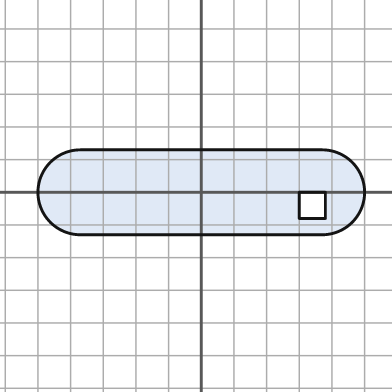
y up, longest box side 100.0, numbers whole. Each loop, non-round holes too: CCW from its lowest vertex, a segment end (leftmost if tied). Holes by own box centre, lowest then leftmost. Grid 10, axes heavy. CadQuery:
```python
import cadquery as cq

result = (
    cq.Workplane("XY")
    .moveTo(-37.0, -13.0)
    .lineTo(37.0, -13.0)
    .threePointArc((50.0, 0.0), (37.0, 13.0))
    .lineTo(-37.0, 13.0)
    .threePointArc((-50.0, 0.0), (-37.0, -13.0))
    .close()
    .moveTo(30.0, -8.0)
    .lineTo(38.0, -8.0)
    .lineTo(38.0, 0.0)
    .lineTo(30.0, 0.0)
    .close()
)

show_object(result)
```